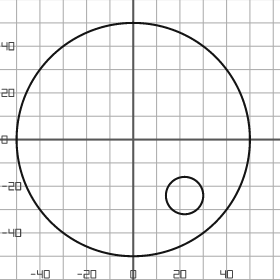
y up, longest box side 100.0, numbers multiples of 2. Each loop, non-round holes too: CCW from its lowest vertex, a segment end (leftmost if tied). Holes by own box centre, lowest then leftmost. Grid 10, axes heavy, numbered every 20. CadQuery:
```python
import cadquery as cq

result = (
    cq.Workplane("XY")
    .moveTo(0.0, 0.0)
    .circle(50.0)
    .moveTo(22.0, -24.0)
    .circle(8.0)
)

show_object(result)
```